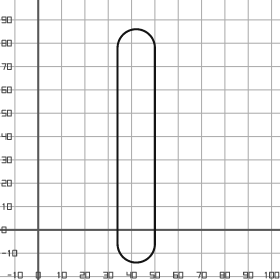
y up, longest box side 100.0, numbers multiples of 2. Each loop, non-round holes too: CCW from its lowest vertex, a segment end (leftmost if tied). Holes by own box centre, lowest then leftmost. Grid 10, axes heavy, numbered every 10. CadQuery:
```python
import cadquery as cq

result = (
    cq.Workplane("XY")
    .moveTo(34.0, -6.0)
    .threePointArc((42.0, -14.0), (50.0, -6.0))
    .lineTo(50.0, 78.0)
    .threePointArc((42.0, 86.0), (34.0, 78.0))
    .close()
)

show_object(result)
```